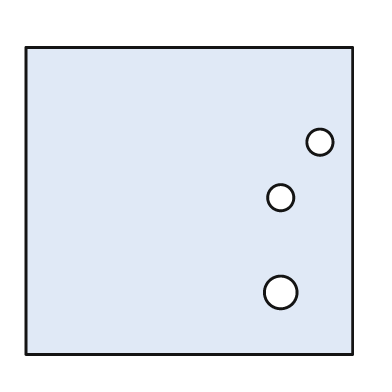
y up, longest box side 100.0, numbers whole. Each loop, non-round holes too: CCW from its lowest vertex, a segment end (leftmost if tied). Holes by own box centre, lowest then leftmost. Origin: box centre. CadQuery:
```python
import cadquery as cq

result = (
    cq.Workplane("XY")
    .moveTo(-50.0, -47.0)
    .lineTo(50.0, -47.0)
    .lineTo(50.0, 47.0)
    .lineTo(-50.0, 47.0)
    .close()
    .moveTo(28.0, -28.0)
    .circle(5.0)
    .moveTo(28.0, 1.0)
    .circle(4.0)
    .moveTo(40.0, 18.0)
    .circle(4.0)
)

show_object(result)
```